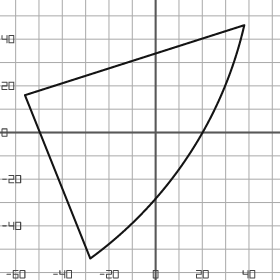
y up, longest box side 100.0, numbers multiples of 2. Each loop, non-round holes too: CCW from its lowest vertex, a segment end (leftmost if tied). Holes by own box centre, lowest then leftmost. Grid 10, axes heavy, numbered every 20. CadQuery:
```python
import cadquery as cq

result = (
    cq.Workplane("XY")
    .moveTo(-28.0, -54.0)
    .threePointArc((14.0, -10.0), (38.0, 46.0))
    .lineTo(-56.0, 16.0)
    .close()
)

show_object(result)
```